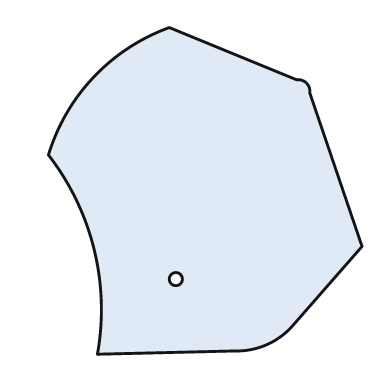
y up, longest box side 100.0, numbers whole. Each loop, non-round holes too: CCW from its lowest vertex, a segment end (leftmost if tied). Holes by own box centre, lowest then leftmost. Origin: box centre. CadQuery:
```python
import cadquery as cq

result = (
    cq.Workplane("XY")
    .moveTo(-33.0, -50.0)
    .lineTo(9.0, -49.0)
    .threePointArc((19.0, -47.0), (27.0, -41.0))
    .lineTo(48.0, -17.0)
    .lineTo(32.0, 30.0)
    .threePointArc((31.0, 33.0), (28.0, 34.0))
    .lineTo(-11.0, 50.0)
    .threePointArc((-34.0, 35.0), (-48.0, 11.0))
    .threePointArc((-34.0, -18.0), (-33.0, -50.0))
    .close()
    .moveTo(-9.0, -27.0)
    .circle(2.0)
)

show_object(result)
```